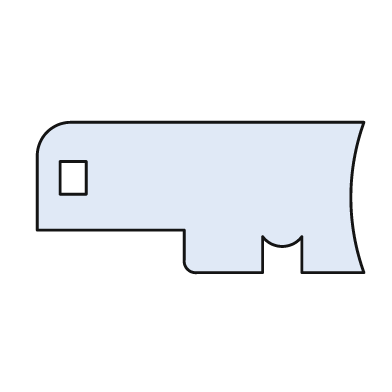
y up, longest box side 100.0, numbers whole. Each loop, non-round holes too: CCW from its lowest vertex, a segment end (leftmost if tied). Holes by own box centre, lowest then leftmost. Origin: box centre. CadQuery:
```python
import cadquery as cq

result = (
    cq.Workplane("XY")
    .moveTo(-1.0, -23.0)
    .lineTo(19.0, -23.0)
    .lineTo(19.0, -12.0)
    .threePointArc((25.0, -15.0), (31.0, -12.0))
    .lineTo(31.0, -23.0)
    .lineTo(50.0, -23.0)
    .threePointArc((46.0, 0.0), (50.0, 23.0))
    .lineTo(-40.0, 23.0)
    .threePointArc((-47.0, 20.0), (-50.0, 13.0))
    .lineTo(-50.0, -10.0)
    .lineTo(-5.0, -10.0)
    .lineTo(-5.0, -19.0)
    .threePointArc((-4.0, -22.0), (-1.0, -23.0))
    .close()
    .moveTo(-43.0, 1.0)
    .lineTo(-35.0, 1.0)
    .lineTo(-35.0, 11.0)
    .lineTo(-43.0, 11.0)
    .close()
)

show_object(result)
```